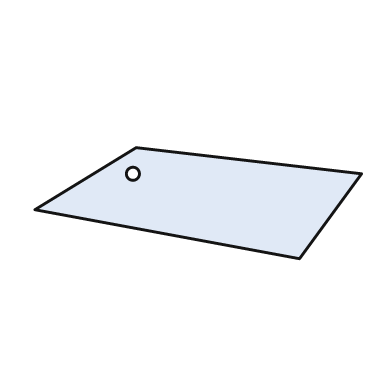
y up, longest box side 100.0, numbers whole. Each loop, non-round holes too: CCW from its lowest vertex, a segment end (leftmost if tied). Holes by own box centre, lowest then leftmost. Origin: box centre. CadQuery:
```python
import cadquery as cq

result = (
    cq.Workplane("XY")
    .moveTo(31.0, -17.0)
    .lineTo(50.0, 9.0)
    .lineTo(-19.0, 17.0)
    .lineTo(-50.0, -2.0)
    .close()
    .moveTo(-20.0, 9.0)
    .circle(2.0)
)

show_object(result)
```